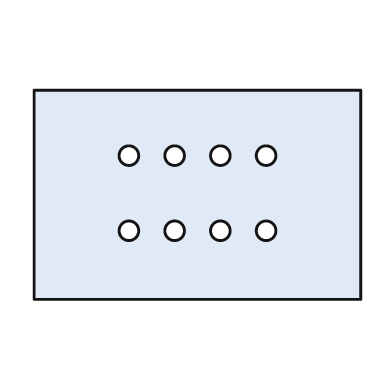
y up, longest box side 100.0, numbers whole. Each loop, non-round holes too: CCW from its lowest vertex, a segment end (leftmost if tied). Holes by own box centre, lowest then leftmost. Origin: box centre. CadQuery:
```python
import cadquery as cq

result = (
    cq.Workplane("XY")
    .moveTo(-50.0, -32.0)
    .lineTo(50.0, -32.0)
    .lineTo(50.0, 32.0)
    .lineTo(-50.0, 32.0)
    .close()
    .moveTo(-21.0, -11.0)
    .circle(3.0)
    .moveTo(-7.0, -11.0)
    .circle(3.0)
    .moveTo(7.0, -11.0)
    .circle(3.0)
    .moveTo(21.0, -11.0)
    .circle(3.0)
    .moveTo(-21.0, 12.0)
    .circle(3.0)
    .moveTo(-7.0, 12.0)
    .circle(3.0)
    .moveTo(7.0, 12.0)
    .circle(3.0)
    .moveTo(21.0, 12.0)
    .circle(3.0)
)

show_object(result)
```